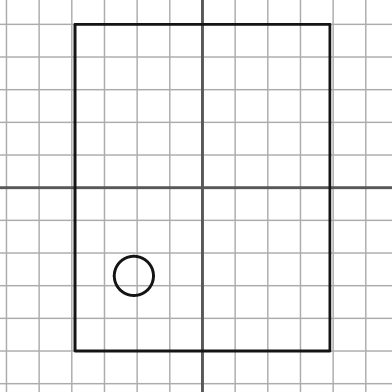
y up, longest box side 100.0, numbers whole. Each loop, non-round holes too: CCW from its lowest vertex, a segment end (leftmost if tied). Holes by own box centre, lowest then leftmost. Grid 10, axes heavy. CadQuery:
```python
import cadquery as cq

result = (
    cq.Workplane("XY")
    .moveTo(-39.0, -50.0)
    .lineTo(39.0, -50.0)
    .lineTo(39.0, 50.0)
    .lineTo(-39.0, 50.0)
    .close()
    .moveTo(-21.0, -27.0)
    .circle(6.0)
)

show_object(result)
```